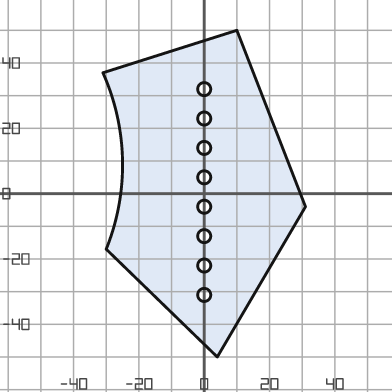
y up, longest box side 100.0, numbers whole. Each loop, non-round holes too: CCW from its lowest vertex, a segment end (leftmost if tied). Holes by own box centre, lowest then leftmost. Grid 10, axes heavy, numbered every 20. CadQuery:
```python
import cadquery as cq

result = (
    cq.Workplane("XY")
    .moveTo(4.0, -50.0)
    .lineTo(31.0, -4.0)
    .lineTo(10.0, 50.0)
    .lineTo(-31.0, 37.0)
    .threePointArc((-25.0, 10.0), (-30.0, -17.0))
    .close()
    .moveTo(0.0, -31.0)
    .circle(2.0)
    .moveTo(0.0, -22.0)
    .circle(2.0)
    .moveTo(0.0, -13.0)
    .circle(2.0)
    .moveTo(0.0, -4.0)
    .circle(2.0)
    .moveTo(0.0, 5.0)
    .circle(2.0)
    .moveTo(0.0, 14.0)
    .circle(2.0)
    .moveTo(0.0, 23.0)
    .circle(2.0)
    .moveTo(0.0, 32.0)
    .circle(2.0)
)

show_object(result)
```